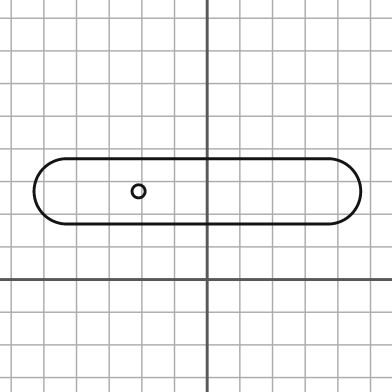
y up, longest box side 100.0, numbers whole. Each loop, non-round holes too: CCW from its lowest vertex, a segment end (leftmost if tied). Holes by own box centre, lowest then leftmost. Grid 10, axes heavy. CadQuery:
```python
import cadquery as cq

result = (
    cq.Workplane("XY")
    .moveTo(-43.0, 17.0)
    .lineTo(37.0, 17.0)
    .threePointArc((47.0, 27.0), (37.0, 37.0))
    .lineTo(-43.0, 37.0)
    .threePointArc((-53.0, 27.0), (-43.0, 17.0))
    .close()
    .moveTo(-21.0, 27.0)
    .circle(2.0)
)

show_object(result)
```